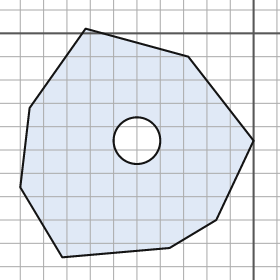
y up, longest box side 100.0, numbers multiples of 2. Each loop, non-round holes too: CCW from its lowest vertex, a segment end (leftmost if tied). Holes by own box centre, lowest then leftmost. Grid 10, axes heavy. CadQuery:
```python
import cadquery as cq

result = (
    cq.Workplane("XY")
    .moveTo(-82.0, -96.0)
    .lineTo(-36.0, -92.0)
    .lineTo(-16.0, -80.0)
    .lineTo(0.0, -46.0)
    .lineTo(-28.0, -10.0)
    .lineTo(-72.0, 2.0)
    .lineTo(-96.0, -32.0)
    .lineTo(-100.0, -66.0)
    .close()
    .moveTo(-50.0, -46.0)
    .circle(10.0)
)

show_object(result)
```